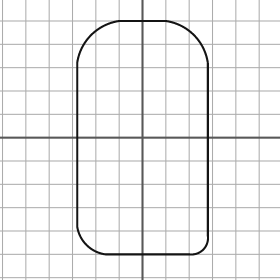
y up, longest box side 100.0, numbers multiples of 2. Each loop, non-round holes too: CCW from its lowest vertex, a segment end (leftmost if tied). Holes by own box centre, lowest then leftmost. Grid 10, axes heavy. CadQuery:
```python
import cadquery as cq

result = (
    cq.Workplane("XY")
    .moveTo(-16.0, -50.0)
    .lineTo(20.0, -50.0)
    .threePointArc((26.0, -48.0), (28.0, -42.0))
    .lineTo(28.0, 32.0)
    .threePointArc((22.0, 44.0), (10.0, 50.0))
    .lineTo(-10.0, 50.0)
    .threePointArc((-22.0, 44.0), (-28.0, 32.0))
    .lineTo(-28.0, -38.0)
    .threePointArc((-24.0, -46.0), (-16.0, -50.0))
    .close()
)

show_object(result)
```